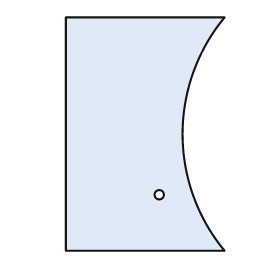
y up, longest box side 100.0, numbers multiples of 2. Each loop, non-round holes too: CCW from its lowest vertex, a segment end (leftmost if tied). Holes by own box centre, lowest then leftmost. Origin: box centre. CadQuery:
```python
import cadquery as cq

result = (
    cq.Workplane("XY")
    .moveTo(-34.0, -50.0)
    .lineTo(34.0, -50.0)
    .threePointArc((16.0, 0.0), (34.0, 50.0))
    .lineTo(-34.0, 50.0)
    .close()
    .moveTo(6.0, -26.0)
    .circle(2.0)
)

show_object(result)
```